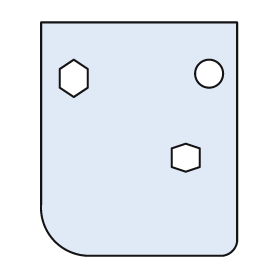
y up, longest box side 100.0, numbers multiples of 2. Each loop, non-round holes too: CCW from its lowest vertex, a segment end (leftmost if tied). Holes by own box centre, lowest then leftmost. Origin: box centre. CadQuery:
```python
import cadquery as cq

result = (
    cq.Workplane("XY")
    .moveTo(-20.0, -50.0)
    .lineTo(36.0, -50.0)
    .threePointArc((40.0, -48.0), (42.0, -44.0))
    .lineTo(42.0, 50.0)
    .lineTo(-42.0, 50.0)
    .lineTo(-42.0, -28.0)
    .threePointArc((-36.0, -44.0), (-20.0, -50.0))
    .close()
    .moveTo(20.0, -14.0)
    .lineTo(26.0, -12.0)
    .lineTo(26.0, -4.0)
    .lineTo(20.0, -2.0)
    .lineTo(14.0, -4.0)
    .lineTo(14.0, -12.0)
    .close()
    .moveTo(-28.0, 18.0)
    .lineTo(-22.0, 22.0)
    .lineTo(-22.0, 30.0)
    .lineTo(-28.0, 34.0)
    .lineTo(-34.0, 30.0)
    .lineTo(-34.0, 22.0)
    .close()
    .moveTo(30.0, 28.0)
    .circle(6.0)
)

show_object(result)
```